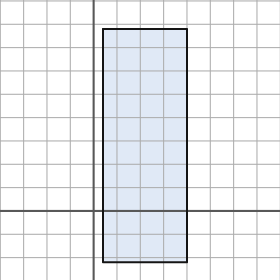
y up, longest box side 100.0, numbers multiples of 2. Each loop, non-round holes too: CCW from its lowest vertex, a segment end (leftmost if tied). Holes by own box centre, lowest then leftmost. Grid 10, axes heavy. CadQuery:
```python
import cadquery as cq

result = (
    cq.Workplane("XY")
    .moveTo(4.0, -22.0)
    .lineTo(40.0, -22.0)
    .lineTo(40.0, 78.0)
    .lineTo(4.0, 78.0)
    .close()
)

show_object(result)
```